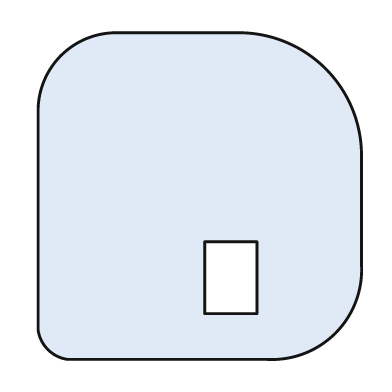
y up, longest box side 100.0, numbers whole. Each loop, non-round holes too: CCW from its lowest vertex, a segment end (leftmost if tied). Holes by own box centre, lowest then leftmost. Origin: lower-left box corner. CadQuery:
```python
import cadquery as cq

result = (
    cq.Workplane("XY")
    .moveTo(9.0, 0.0)
    .lineTo(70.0, 0.0)
    .threePointArc((91.0, 8.0), (99.0, 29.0))
    .lineTo(99.0, 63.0)
    .threePointArc((88.0, 89.0), (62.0, 100.0))
    .lineTo(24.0, 100.0)
    .threePointArc((7.0, 93.0), (0.0, 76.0))
    .lineTo(0.0, 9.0)
    .threePointArc((3.0, 3.0), (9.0, 0.0))
    .close()
    .moveTo(51.0, 14.0)
    .lineTo(67.0, 14.0)
    .lineTo(67.0, 36.0)
    .lineTo(51.0, 36.0)
    .close()
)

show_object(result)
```